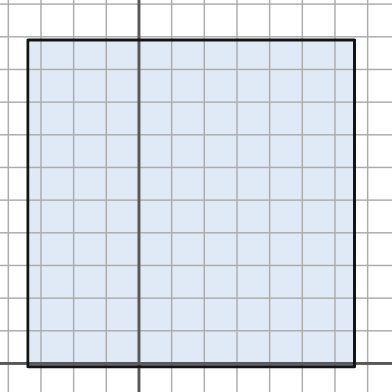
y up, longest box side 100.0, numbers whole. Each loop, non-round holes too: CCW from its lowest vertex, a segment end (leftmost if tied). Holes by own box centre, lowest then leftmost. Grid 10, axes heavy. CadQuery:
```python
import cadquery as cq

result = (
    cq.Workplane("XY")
    .moveTo(-34.0, -1.0)
    .lineTo(66.0, -1.0)
    .lineTo(66.0, 99.0)
    .lineTo(-34.0, 99.0)
    .close()
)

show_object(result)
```